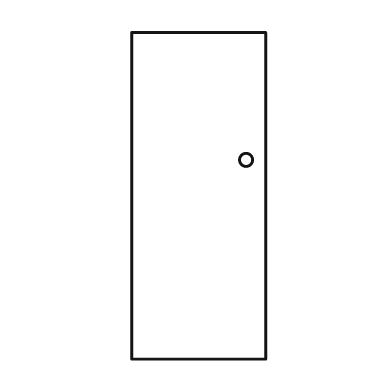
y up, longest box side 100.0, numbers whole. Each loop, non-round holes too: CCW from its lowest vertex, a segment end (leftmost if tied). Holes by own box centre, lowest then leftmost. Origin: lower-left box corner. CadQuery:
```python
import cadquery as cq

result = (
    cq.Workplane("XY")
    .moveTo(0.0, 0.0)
    .lineTo(41.0, 0.0)
    .lineTo(41.0, 100.0)
    .lineTo(0.0, 100.0)
    .close()
    .moveTo(35.0, 61.0)
    .circle(2.0)
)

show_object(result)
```